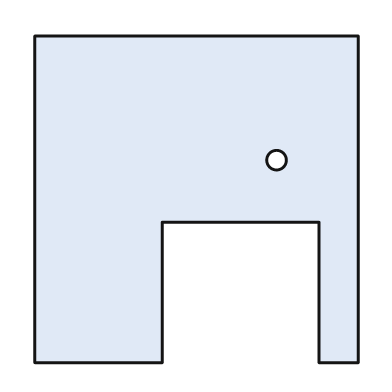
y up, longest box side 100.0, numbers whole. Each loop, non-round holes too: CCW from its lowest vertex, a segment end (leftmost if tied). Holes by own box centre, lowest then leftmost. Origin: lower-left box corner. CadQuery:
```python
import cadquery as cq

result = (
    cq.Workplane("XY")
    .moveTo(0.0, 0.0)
    .lineTo(39.0, 0.0)
    .lineTo(39.0, 43.0)
    .lineTo(87.0, 43.0)
    .lineTo(87.0, 0.0)
    .lineTo(99.0, 0.0)
    .lineTo(99.0, 100.0)
    .lineTo(0.0, 100.0)
    .close()
    .moveTo(74.0, 62.0)
    .circle(3.0)
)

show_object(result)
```